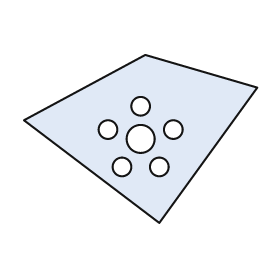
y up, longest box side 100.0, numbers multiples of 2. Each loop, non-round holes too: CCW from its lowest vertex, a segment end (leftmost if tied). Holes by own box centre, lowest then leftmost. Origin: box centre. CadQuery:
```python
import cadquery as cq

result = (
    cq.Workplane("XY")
    .moveTo(8.0, -36.0)
    .lineTo(50.0, 22.0)
    .lineTo(2.0, 36.0)
    .lineTo(-50.0, 8.0)
    .close()
    .moveTo(-8.0, -12.0)
    .circle(4.0)
    .moveTo(8.0, -12.0)
    .circle(4.0)
    .moveTo(0.0, 0.0)
    .circle(6.0)
    .moveTo(-14.0, 4.0)
    .circle(4.0)
    .moveTo(14.0, 4.0)
    .circle(4.0)
    .moveTo(0.0, 14.0)
    .circle(4.0)
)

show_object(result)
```